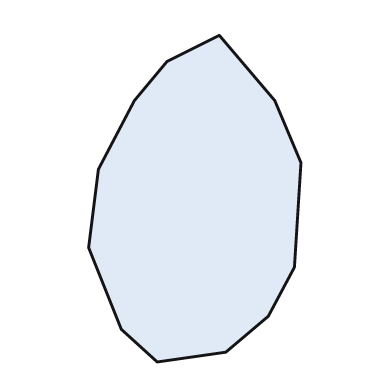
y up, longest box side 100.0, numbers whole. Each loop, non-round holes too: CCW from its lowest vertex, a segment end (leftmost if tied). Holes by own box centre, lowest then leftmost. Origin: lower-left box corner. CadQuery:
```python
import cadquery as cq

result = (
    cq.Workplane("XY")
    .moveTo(21.0, 0.0)
    .lineTo(42.0, 3.0)
    .lineTo(55.0, 14.0)
    .lineTo(63.0, 29.0)
    .lineTo(65.0, 61.0)
    .lineTo(57.0, 80.0)
    .lineTo(40.0, 100.0)
    .lineTo(24.0, 92.0)
    .lineTo(14.0, 80.0)
    .lineTo(3.0, 59.0)
    .lineTo(0.0, 35.0)
    .lineTo(10.0, 10.0)
    .close()
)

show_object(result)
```